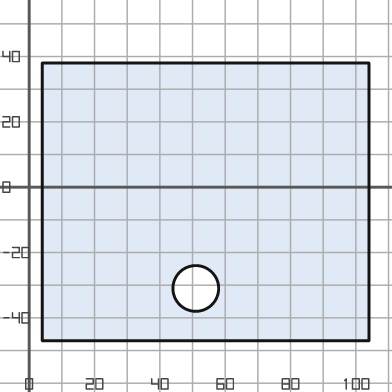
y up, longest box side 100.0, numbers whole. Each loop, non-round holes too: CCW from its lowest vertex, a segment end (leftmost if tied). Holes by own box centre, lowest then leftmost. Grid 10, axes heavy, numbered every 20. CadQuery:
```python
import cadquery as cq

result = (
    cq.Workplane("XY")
    .moveTo(4.0, -47.0)
    .lineTo(104.0, -47.0)
    .lineTo(104.0, 38.0)
    .lineTo(4.0, 38.0)
    .close()
    .moveTo(51.0, -31.0)
    .circle(7.0)
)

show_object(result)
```